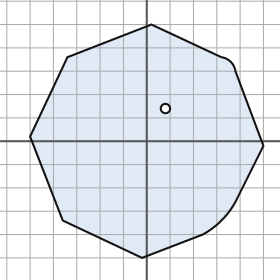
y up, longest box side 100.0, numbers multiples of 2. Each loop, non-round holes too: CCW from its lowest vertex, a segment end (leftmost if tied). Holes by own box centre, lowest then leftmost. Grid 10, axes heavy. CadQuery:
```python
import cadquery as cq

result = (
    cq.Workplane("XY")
    .moveTo(-2.0, -50.0)
    .lineTo(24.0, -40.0)
    .threePointArc((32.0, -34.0), (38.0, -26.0))
    .lineTo(50.0, -2.0)
    .lineTo(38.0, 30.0)
    .threePointArc((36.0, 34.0), (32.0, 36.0))
    .lineTo(2.0, 50.0)
    .lineTo(-34.0, 36.0)
    .lineTo(-50.0, 2.0)
    .lineTo(-36.0, -34.0)
    .close()
    .moveTo(8.0, 14.0)
    .circle(2.0)
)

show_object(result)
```